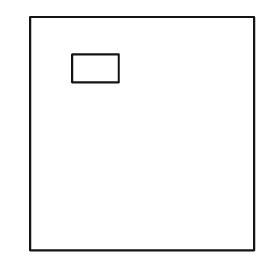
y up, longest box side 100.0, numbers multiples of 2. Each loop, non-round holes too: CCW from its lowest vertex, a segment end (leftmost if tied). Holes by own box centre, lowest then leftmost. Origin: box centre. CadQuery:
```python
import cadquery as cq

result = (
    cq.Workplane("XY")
    .moveTo(-48.0, -50.0)
    .lineTo(48.0, -50.0)
    .lineTo(48.0, 50.0)
    .lineTo(-48.0, 50.0)
    .close()
    .moveTo(-30.0, 22.0)
    .lineTo(-10.0, 22.0)
    .lineTo(-10.0, 34.0)
    .lineTo(-30.0, 34.0)
    .close()
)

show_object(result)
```